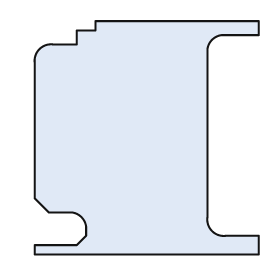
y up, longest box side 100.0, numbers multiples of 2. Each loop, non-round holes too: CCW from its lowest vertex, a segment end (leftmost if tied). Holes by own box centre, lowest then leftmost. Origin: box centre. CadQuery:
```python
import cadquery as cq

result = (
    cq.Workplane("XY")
    .moveTo(-48.0, -50.0)
    .lineTo(48.0, -50.0)
    .lineTo(48.0, -42.0)
    .lineTo(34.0, -42.0)
    .threePointArc((28.0, -40.0), (26.0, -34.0))
    .lineTo(26.0, 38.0)
    .threePointArc((28.0, 42.0), (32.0, 44.0))
    .lineTo(48.0, 44.0)
    .lineTo(48.0, 50.0)
    .lineTo(-22.0, 50.0)
    .lineTo(-22.0, 46.0)
    .lineTo(-30.0, 46.0)
    .lineTo(-30.0, 40.0)
    .lineTo(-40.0, 40.0)
    .threePointArc((-46.0, 38.0), (-48.0, 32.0))
    .lineTo(-48.0, -26.0)
    .lineTo(-42.0, -32.0)
    .lineTo(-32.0, -32.0)
    .threePointArc((-28.0, -34.0), (-26.0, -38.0))
    .lineTo(-26.0, -42.0)
    .lineTo(-30.0, -46.0)
    .lineTo(-48.0, -46.0)
    .close()
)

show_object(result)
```